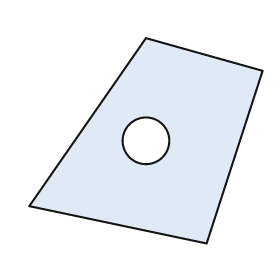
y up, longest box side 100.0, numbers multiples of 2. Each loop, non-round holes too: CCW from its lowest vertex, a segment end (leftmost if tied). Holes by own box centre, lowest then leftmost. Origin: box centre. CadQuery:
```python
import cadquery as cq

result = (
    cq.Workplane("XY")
    .moveTo(26.0, -44.0)
    .lineTo(50.0, 30.0)
    .lineTo(0.0, 44.0)
    .lineTo(-50.0, -28.0)
    .close()
    .moveTo(0.0, 0.0)
    .circle(10.0)
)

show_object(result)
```